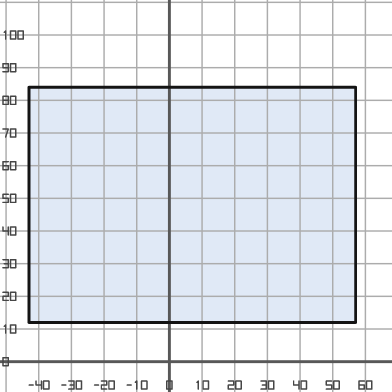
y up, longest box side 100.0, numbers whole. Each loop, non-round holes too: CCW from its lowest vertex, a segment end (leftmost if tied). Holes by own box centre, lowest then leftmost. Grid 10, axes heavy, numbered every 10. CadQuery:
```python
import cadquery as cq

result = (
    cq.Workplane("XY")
    .moveTo(-43.0, 12.0)
    .lineTo(57.0, 12.0)
    .lineTo(57.0, 84.0)
    .lineTo(-43.0, 84.0)
    .close()
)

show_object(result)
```